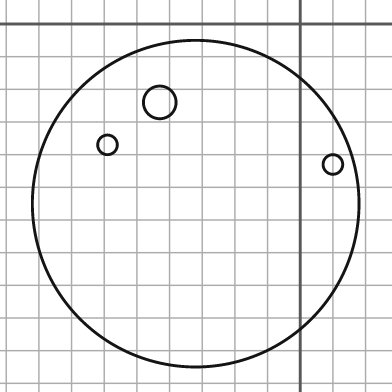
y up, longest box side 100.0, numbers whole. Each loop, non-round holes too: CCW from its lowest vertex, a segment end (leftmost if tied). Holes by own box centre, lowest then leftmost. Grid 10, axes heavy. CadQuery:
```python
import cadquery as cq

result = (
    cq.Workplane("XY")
    .moveTo(-32.0, -55.0)
    .circle(50.0)
    .moveTo(10.0, -43.0)
    .circle(3.0)
    .moveTo(-59.0, -37.0)
    .circle(3.0)
    .moveTo(-43.0, -24.0)
    .circle(5.0)
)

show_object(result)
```